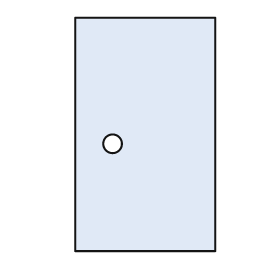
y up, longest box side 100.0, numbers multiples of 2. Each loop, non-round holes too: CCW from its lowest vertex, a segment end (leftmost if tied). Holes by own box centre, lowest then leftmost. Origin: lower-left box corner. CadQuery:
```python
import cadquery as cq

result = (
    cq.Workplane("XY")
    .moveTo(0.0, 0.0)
    .lineTo(60.0, 0.0)
    .lineTo(60.0, 100.0)
    .lineTo(0.0, 100.0)
    .close()
    .moveTo(16.0, 46.0)
    .circle(4.0)
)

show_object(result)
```